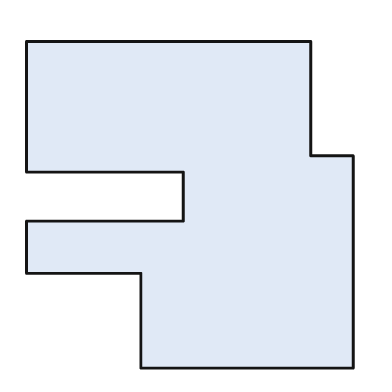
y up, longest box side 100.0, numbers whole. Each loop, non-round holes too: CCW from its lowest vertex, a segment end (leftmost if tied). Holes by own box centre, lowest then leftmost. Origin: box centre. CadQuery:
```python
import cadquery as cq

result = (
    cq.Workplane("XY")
    .moveTo(-15.0, -50.0)
    .lineTo(50.0, -50.0)
    .lineTo(50.0, 15.0)
    .lineTo(37.0, 15.0)
    .lineTo(37.0, 50.0)
    .lineTo(-50.0, 50.0)
    .lineTo(-50.0, 10.0)
    .lineTo(-2.0, 10.0)
    .lineTo(-2.0, -5.0)
    .lineTo(-50.0, -5.0)
    .lineTo(-50.0, -21.0)
    .lineTo(-15.0, -21.0)
    .close()
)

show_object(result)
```